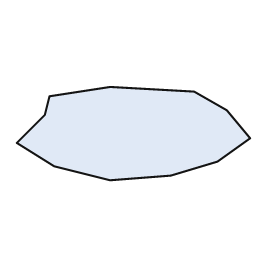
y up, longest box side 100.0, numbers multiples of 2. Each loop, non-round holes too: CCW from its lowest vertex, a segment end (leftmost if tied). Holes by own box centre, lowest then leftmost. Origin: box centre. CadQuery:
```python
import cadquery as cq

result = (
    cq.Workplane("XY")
    .moveTo(-10.0, -20.0)
    .lineTo(16.0, -18.0)
    .lineTo(36.0, -12.0)
    .lineTo(50.0, -2.0)
    .lineTo(40.0, 10.0)
    .lineTo(26.0, 18.0)
    .lineTo(-10.0, 20.0)
    .lineTo(-36.0, 16.0)
    .lineTo(-38.0, 8.0)
    .lineTo(-50.0, -4.0)
    .lineTo(-34.0, -14.0)
    .close()
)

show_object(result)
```